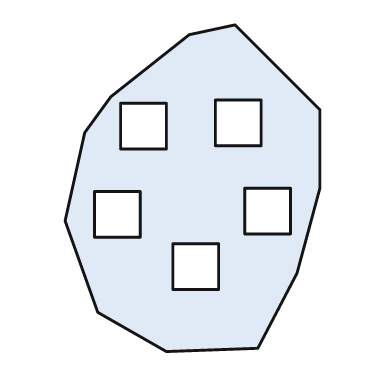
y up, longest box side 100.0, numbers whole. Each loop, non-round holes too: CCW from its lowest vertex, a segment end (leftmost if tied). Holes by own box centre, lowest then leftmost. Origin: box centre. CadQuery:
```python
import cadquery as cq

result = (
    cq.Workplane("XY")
    .moveTo(-8.0, -50.0)
    .lineTo(20.0, -49.0)
    .lineTo(32.0, -26.0)
    .lineTo(39.0, 0.0)
    .lineTo(39.0, 24.0)
    .lineTo(13.0, 50.0)
    .lineTo(-1.0, 47.0)
    .lineTo(-25.0, 28.0)
    .lineTo(-33.0, 17.0)
    .lineTo(-39.0, -10.0)
    .lineTo(-29.0, -38.0)
    .close()
    .moveTo(-6.0, -31.0)
    .lineTo(8.0, -31.0)
    .lineTo(8.0, -17.0)
    .lineTo(-6.0, -17.0)
    .close()
    .moveTo(-30.0, -15.0)
    .lineTo(-16.0, -15.0)
    .lineTo(-16.0, -1.0)
    .lineTo(-30.0, -1.0)
    .close()
    .moveTo(16.0, -14.0)
    .lineTo(30.0, -14.0)
    .lineTo(30.0, 0.0)
    .lineTo(16.0, 0.0)
    .close()
    .moveTo(-22.0, 12.0)
    .lineTo(-8.0, 12.0)
    .lineTo(-8.0, 26.0)
    .lineTo(-22.0, 26.0)
    .close()
    .moveTo(7.0, 13.0)
    .lineTo(21.0, 13.0)
    .lineTo(21.0, 27.0)
    .lineTo(7.0, 27.0)
    .close()
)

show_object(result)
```